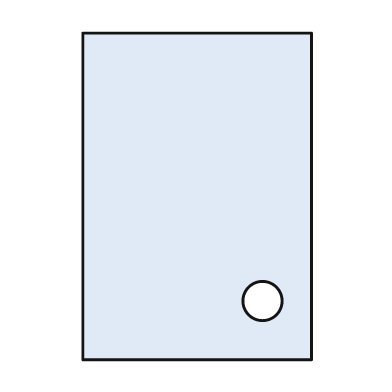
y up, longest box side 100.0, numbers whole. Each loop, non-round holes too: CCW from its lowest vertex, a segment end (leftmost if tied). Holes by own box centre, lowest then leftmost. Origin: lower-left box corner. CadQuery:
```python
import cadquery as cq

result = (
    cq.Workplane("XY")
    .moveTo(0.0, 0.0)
    .lineTo(70.0, 0.0)
    .lineTo(70.0, 100.0)
    .lineTo(0.0, 100.0)
    .close()
    .moveTo(55.0, 18.0)
    .circle(6.0)
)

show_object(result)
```